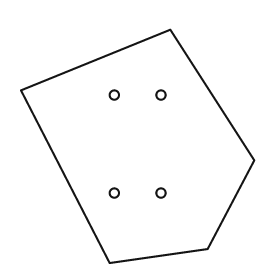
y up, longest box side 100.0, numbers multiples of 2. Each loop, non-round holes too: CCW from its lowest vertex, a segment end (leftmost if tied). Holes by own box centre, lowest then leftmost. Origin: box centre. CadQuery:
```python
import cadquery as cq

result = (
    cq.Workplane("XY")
    .moveTo(-12.0, -50.0)
    .lineTo(30.0, -44.0)
    .lineTo(50.0, -6.0)
    .lineTo(14.0, 50.0)
    .lineTo(-50.0, 24.0)
    .close()
    .moveTo(-10.0, -20.0)
    .circle(2.0)
    .moveTo(10.0, -20.0)
    .circle(2.0)
    .moveTo(-10.0, 22.0)
    .circle(2.0)
    .moveTo(10.0, 22.0)
    .circle(2.0)
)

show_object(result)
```